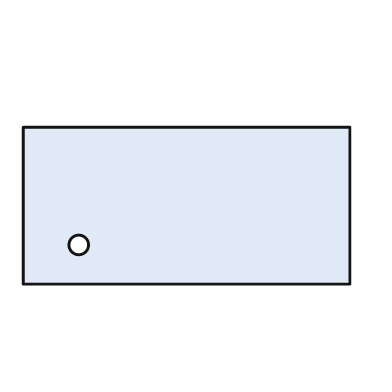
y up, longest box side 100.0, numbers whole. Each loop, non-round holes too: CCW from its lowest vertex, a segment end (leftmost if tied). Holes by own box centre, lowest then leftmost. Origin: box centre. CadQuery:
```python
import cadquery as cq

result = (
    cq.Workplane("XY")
    .moveTo(-50.0, -24.0)
    .lineTo(50.0, -24.0)
    .lineTo(50.0, 24.0)
    .lineTo(-50.0, 24.0)
    .close()
    .moveTo(-33.0, -12.0)
    .circle(3.0)
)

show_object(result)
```